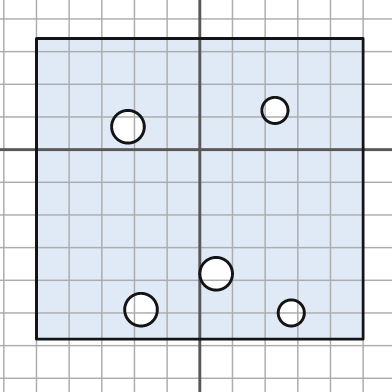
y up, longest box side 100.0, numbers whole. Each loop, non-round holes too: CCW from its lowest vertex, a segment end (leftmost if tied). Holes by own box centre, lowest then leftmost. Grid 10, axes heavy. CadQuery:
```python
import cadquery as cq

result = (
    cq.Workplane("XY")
    .moveTo(-50.0, -58.0)
    .lineTo(50.0, -58.0)
    .lineTo(50.0, 34.0)
    .lineTo(-50.0, 34.0)
    .close()
    .moveTo(28.0, -50.0)
    .circle(4.0)
    .moveTo(-18.0, -49.0)
    .circle(5.0)
    .moveTo(5.0, -38.0)
    .circle(5.0)
    .moveTo(-22.0, 7.0)
    .circle(5.0)
    .moveTo(23.0, 12.0)
    .circle(4.0)
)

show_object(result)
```